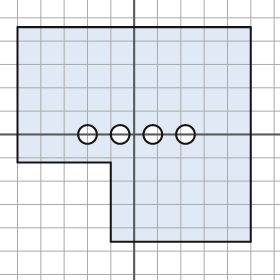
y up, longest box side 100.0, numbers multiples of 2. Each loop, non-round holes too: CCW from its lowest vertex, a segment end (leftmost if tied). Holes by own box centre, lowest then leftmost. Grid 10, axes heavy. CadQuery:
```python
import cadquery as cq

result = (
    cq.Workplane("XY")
    .moveTo(-10.0, -46.0)
    .lineTo(50.0, -46.0)
    .lineTo(50.0, 46.0)
    .lineTo(-50.0, 46.0)
    .lineTo(-50.0, -12.0)
    .lineTo(-10.0, -12.0)
    .close()
    .moveTo(-20.0, 0.0)
    .circle(4.0)
    .moveTo(-6.0, 0.0)
    .circle(4.0)
    .moveTo(8.0, 0.0)
    .circle(4.0)
    .moveTo(22.0, 0.0)
    .circle(4.0)
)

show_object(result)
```